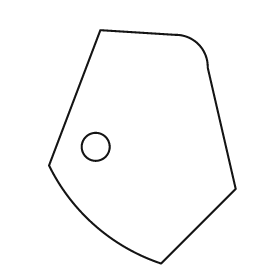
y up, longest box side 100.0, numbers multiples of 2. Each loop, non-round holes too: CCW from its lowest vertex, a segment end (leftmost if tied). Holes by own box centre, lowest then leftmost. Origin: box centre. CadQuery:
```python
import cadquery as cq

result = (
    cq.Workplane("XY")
    .moveTo(8.0, -50.0)
    .lineTo(40.0, -18.0)
    .lineTo(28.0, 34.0)
    .threePointArc((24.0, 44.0), (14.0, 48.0))
    .lineTo(-18.0, 50.0)
    .lineTo(-40.0, -8.0)
    .threePointArc((-20.0, -34.0), (8.0, -50.0))
    .close()
    .moveTo(-20.0, 0.0)
    .circle(6.0)
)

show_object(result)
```